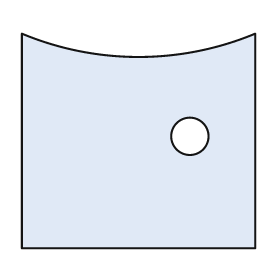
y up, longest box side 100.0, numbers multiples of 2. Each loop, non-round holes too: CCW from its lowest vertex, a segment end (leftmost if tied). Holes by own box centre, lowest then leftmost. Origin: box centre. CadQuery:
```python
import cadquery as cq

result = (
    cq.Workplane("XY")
    .moveTo(-50.0, -46.0)
    .lineTo(50.0, -46.0)
    .lineTo(50.0, 46.0)
    .threePointArc((0.0, 36.0), (-50.0, 46.0))
    .close()
    .moveTo(22.0, 2.0)
    .circle(8.0)
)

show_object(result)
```